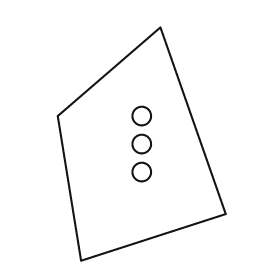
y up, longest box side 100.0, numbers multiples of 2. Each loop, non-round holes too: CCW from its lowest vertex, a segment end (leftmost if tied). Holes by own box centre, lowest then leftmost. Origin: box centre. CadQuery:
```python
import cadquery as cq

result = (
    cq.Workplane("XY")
    .moveTo(-26.0, -50.0)
    .lineTo(36.0, -30.0)
    .lineTo(8.0, 50.0)
    .lineTo(-36.0, 12.0)
    .close()
    .moveTo(0.0, -12.0)
    .circle(4.0)
    .moveTo(0.0, 0.0)
    .circle(4.0)
    .moveTo(0.0, 12.0)
    .circle(4.0)
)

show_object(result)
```